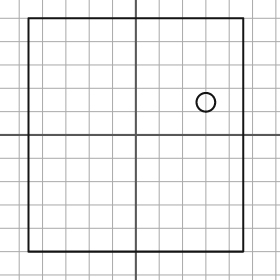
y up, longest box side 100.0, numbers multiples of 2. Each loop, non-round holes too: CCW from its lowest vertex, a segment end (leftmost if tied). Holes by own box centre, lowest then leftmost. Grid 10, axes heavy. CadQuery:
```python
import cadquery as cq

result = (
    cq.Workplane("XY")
    .moveTo(-46.0, -50.0)
    .lineTo(46.0, -50.0)
    .lineTo(46.0, 50.0)
    .lineTo(-46.0, 50.0)
    .close()
    .moveTo(30.0, 14.0)
    .circle(4.0)
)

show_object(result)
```